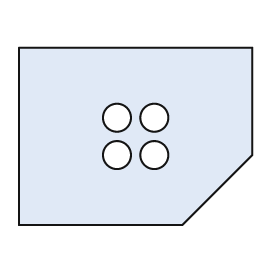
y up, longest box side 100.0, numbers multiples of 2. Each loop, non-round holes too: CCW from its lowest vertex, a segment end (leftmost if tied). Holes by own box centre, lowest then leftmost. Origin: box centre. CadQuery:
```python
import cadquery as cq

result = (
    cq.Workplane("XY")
    .moveTo(-50.0, -38.0)
    .lineTo(20.0, -38.0)
    .lineTo(50.0, -8.0)
    .lineTo(50.0, 38.0)
    .lineTo(-50.0, 38.0)
    .close()
    .moveTo(-8.0, -8.0)
    .circle(6.0)
    .moveTo(8.0, -8.0)
    .circle(6.0)
    .moveTo(-8.0, 8.0)
    .circle(6.0)
    .moveTo(8.0, 8.0)
    .circle(6.0)
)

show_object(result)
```